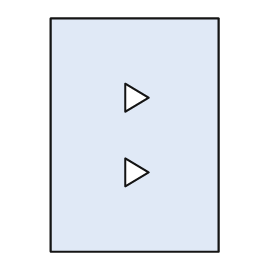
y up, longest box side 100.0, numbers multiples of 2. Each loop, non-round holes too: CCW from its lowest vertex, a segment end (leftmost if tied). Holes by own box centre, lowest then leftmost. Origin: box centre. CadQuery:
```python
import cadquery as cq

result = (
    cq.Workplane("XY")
    .moveTo(-36.0, -50.0)
    .lineTo(36.0, -50.0)
    .lineTo(36.0, 50.0)
    .lineTo(-36.0, 50.0)
    .close()
    .moveTo(-4.0, -22.0)
    .lineTo(6.0, -16.0)
    .lineTo(-4.0, -10.0)
    .close()
    .moveTo(-4.0, 10.0)
    .lineTo(6.0, 16.0)
    .lineTo(-4.0, 22.0)
    .close()
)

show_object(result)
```